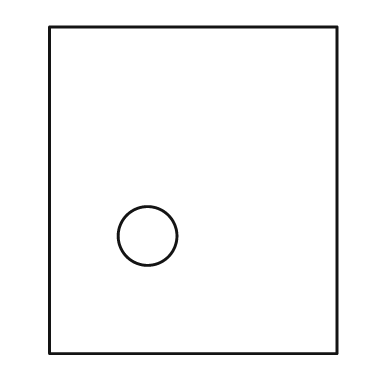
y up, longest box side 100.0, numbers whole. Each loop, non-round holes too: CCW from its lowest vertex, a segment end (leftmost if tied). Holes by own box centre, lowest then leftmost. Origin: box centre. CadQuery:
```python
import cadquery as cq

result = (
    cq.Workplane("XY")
    .moveTo(-44.0, -50.0)
    .lineTo(44.0, -50.0)
    .lineTo(44.0, 50.0)
    .lineTo(-44.0, 50.0)
    .close()
    .moveTo(-14.0, -14.0)
    .circle(9.0)
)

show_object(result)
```